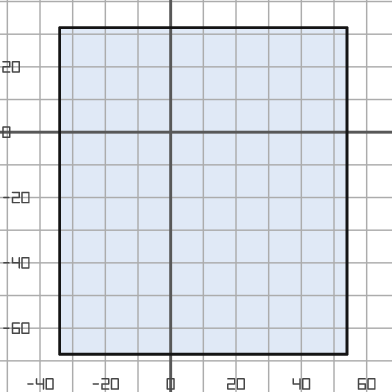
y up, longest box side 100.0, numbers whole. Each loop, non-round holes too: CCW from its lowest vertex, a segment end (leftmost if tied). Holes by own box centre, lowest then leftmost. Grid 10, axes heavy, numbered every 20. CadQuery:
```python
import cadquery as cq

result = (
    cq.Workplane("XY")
    .moveTo(-34.0, -68.0)
    .lineTo(54.0, -68.0)
    .lineTo(54.0, 32.0)
    .lineTo(-34.0, 32.0)
    .close()
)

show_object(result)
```